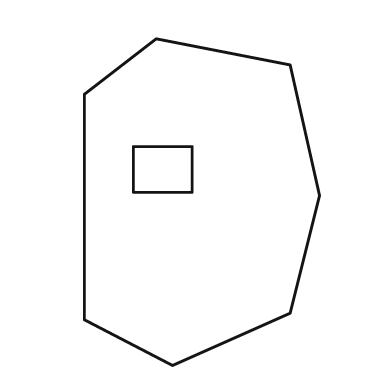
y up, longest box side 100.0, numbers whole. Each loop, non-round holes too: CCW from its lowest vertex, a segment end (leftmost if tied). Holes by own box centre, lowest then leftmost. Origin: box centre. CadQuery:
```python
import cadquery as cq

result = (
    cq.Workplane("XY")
    .moveTo(-9.0, -50.0)
    .lineTo(27.0, -34.0)
    .lineTo(36.0, 2.0)
    .lineTo(27.0, 42.0)
    .lineTo(-14.0, 50.0)
    .lineTo(-36.0, 33.0)
    .lineTo(-36.0, -36.0)
    .close()
    .moveTo(-21.0, 3.0)
    .lineTo(-3.0, 3.0)
    .lineTo(-3.0, 17.0)
    .lineTo(-21.0, 17.0)
    .close()
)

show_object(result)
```